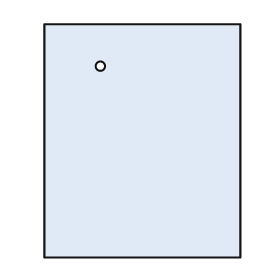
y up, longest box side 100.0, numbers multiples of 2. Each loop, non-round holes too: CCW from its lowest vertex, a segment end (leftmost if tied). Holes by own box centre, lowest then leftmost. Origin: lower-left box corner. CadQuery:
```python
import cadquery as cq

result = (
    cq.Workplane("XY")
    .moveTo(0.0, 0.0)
    .lineTo(84.0, 0.0)
    .lineTo(84.0, 100.0)
    .lineTo(0.0, 100.0)
    .close()
    .moveTo(24.0, 82.0)
    .circle(2.0)
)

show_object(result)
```